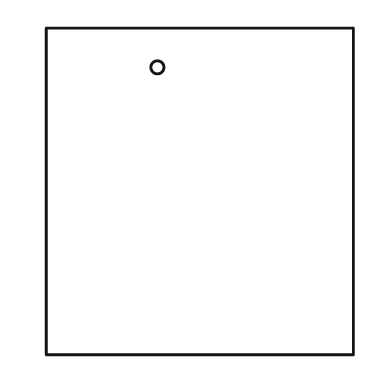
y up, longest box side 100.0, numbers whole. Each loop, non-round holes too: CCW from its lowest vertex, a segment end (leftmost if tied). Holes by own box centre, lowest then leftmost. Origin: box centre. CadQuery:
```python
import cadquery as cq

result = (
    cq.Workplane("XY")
    .moveTo(-47.0, -50.0)
    .lineTo(47.0, -50.0)
    .lineTo(47.0, 50.0)
    .lineTo(-47.0, 50.0)
    .close()
    .moveTo(-13.0, 38.0)
    .circle(2.0)
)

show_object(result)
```